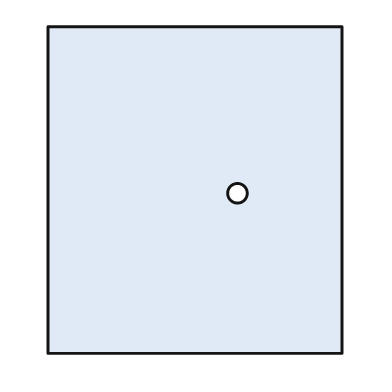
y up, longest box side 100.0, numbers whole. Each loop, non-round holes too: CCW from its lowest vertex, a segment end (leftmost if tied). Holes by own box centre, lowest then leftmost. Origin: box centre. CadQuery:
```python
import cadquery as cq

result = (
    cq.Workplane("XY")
    .moveTo(-45.0, -50.0)
    .lineTo(45.0, -50.0)
    .lineTo(45.0, 50.0)
    .lineTo(-45.0, 50.0)
    .close()
    .moveTo(13.0, -1.0)
    .circle(3.0)
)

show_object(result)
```